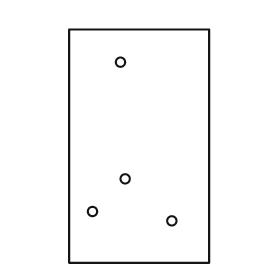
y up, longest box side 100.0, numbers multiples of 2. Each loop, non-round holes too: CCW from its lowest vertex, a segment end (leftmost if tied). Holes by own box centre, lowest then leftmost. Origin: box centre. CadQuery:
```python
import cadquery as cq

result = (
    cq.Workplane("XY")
    .moveTo(-30.0, -50.0)
    .lineTo(30.0, -50.0)
    .lineTo(30.0, 50.0)
    .lineTo(-30.0, 50.0)
    .close()
    .moveTo(14.0, -32.0)
    .circle(2.0)
    .moveTo(-20.0, -28.0)
    .circle(2.0)
    .moveTo(-6.0, -14.0)
    .circle(2.0)
    .moveTo(-8.0, 36.0)
    .circle(2.0)
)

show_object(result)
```